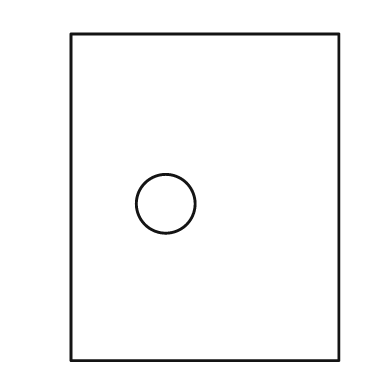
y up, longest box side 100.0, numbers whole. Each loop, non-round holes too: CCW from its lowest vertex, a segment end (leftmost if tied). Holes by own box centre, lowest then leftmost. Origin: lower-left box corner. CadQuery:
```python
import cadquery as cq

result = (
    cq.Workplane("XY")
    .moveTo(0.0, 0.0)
    .lineTo(82.0, 0.0)
    .lineTo(82.0, 100.0)
    .lineTo(0.0, 100.0)
    .close()
    .moveTo(29.0, 48.0)
    .circle(9.0)
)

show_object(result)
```